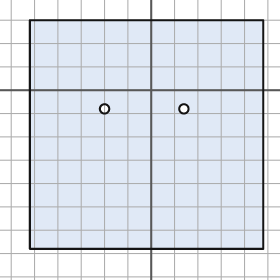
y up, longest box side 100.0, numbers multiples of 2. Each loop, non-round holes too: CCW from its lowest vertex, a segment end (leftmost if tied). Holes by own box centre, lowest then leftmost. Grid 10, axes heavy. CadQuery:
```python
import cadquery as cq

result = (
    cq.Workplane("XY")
    .moveTo(-52.0, -68.0)
    .lineTo(48.0, -68.0)
    .lineTo(48.0, 30.0)
    .lineTo(-52.0, 30.0)
    .close()
    .moveTo(-20.0, -8.0)
    .circle(2.0)
    .moveTo(14.0, -8.0)
    .circle(2.0)
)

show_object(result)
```